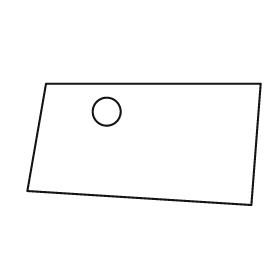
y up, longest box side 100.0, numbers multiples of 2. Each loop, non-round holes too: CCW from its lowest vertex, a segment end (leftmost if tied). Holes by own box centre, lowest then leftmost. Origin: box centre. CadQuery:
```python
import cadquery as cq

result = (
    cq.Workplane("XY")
    .moveTo(46.0, -26.0)
    .lineTo(50.0, 26.0)
    .lineTo(-42.0, 26.0)
    .lineTo(-50.0, -20.0)
    .close()
    .moveTo(-16.0, 14.0)
    .circle(6.0)
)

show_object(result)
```